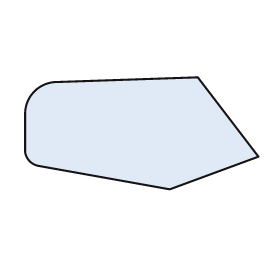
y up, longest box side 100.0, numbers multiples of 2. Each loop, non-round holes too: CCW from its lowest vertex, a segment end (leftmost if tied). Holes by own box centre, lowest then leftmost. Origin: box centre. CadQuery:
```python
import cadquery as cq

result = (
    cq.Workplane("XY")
    .moveTo(12.0, -24.0)
    .lineTo(50.0, -10.0)
    .lineTo(24.0, 24.0)
    .lineTo(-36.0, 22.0)
    .threePointArc((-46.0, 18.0), (-50.0, 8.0))
    .lineTo(-50.0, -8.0)
    .threePointArc((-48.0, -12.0), (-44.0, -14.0))
    .close()
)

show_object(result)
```